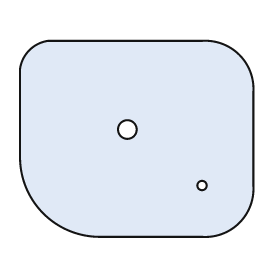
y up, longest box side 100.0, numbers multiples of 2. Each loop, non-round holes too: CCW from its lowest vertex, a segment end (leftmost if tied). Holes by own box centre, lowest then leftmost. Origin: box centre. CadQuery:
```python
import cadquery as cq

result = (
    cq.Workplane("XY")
    .moveTo(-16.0, -42.0)
    .lineTo(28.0, -42.0)
    .threePointArc((44.0, -36.0), (50.0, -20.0))
    .lineTo(50.0, 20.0)
    .threePointArc((44.0, 36.0), (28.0, 42.0))
    .lineTo(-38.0, 42.0)
    .threePointArc((-46.0, 38.0), (-50.0, 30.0))
    .lineTo(-50.0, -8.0)
    .threePointArc((-40.0, -32.0), (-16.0, -42.0))
    .close()
    .moveTo(28.0, -20.0)
    .circle(2.0)
    .moveTo(-4.0, 4.0)
    .circle(4.0)
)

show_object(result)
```